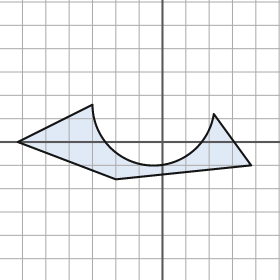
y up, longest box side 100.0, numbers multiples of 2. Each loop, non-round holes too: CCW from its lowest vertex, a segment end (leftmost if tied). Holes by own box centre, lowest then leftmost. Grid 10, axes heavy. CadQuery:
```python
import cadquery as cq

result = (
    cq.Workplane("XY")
    .moveTo(-20.0, -16.0)
    .lineTo(38.0, -10.0)
    .lineTo(22.0, 12.0)
    .threePointArc((-6.0, -10.0), (-30.0, 16.0))
    .lineTo(-62.0, 0.0)
    .close()
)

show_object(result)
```